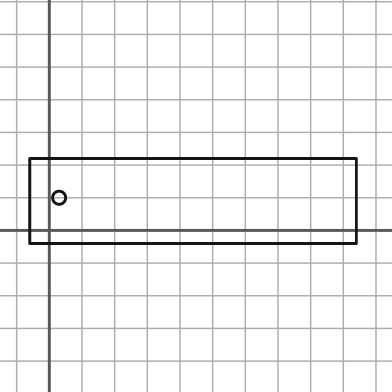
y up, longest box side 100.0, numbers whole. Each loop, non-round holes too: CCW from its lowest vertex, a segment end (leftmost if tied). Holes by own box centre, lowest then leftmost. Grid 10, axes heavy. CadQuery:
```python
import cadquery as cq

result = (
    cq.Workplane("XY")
    .moveTo(-6.0, -4.0)
    .lineTo(94.0, -4.0)
    .lineTo(94.0, 22.0)
    .lineTo(-6.0, 22.0)
    .close()
    .moveTo(3.0, 10.0)
    .circle(2.0)
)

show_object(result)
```